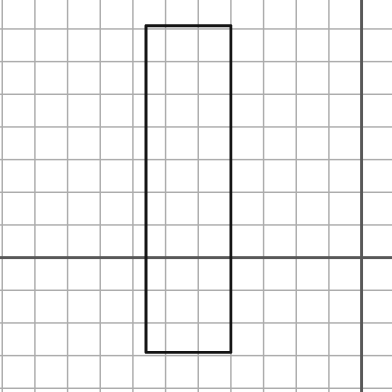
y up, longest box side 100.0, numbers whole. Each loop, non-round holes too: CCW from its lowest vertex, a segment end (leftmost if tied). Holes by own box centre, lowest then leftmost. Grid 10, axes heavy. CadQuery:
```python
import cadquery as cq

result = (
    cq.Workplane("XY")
    .moveTo(-66.0, -29.0)
    .lineTo(-40.0, -29.0)
    .lineTo(-40.0, 71.0)
    .lineTo(-66.0, 71.0)
    .close()
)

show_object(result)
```